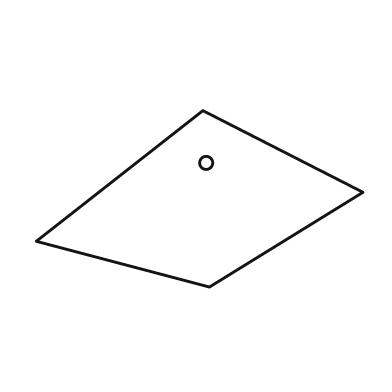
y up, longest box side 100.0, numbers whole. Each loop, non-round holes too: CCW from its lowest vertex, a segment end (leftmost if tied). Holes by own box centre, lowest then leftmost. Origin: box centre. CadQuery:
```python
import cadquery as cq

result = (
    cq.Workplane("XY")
    .moveTo(3.0, -27.0)
    .lineTo(50.0, 2.0)
    .lineTo(1.0, 27.0)
    .lineTo(-50.0, -13.0)
    .close()
    .moveTo(2.0, 11.0)
    .circle(2.0)
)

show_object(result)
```